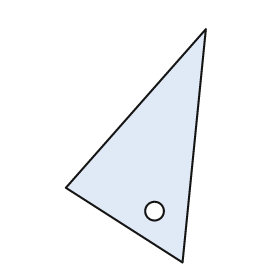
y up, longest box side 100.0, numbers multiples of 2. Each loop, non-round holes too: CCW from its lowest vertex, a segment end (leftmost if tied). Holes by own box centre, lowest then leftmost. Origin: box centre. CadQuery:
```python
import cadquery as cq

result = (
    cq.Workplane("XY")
    .moveTo(20.0, -50.0)
    .lineTo(30.0, 50.0)
    .lineTo(-30.0, -18.0)
    .close()
    .moveTo(8.0, -28.0)
    .circle(4.0)
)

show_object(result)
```